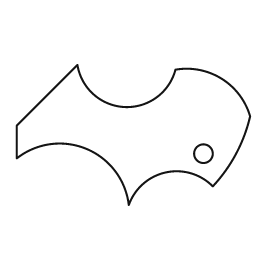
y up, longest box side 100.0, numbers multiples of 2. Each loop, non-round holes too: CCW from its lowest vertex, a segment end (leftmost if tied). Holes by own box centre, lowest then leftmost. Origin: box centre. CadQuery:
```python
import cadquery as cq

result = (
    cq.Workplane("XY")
    .moveTo(-2.0, -30.0)
    .threePointArc((14.0, -16.0), (34.0, -22.0))
    .threePointArc((44.0, -8.0), (50.0, 8.0))
    .threePointArc((38.0, 24.0), (18.0, 28.0))
    .threePointArc((-4.0, 12.0), (-24.0, 30.0))
    .lineTo(-50.0, 4.0)
    .lineTo(-50.0, -10.0)
    .threePointArc((-20.0, -6.0), (-2.0, -30.0))
    .close()
    .moveTo(30.0, -8.0)
    .circle(4.0)
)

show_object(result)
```